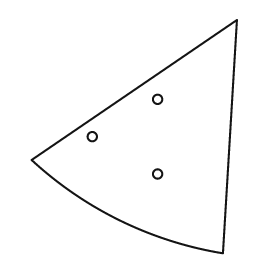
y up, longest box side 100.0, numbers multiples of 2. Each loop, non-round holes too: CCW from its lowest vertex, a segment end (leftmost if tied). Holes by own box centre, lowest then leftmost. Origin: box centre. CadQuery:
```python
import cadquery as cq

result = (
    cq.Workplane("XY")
    .moveTo(38.0, -50.0)
    .lineTo(44.0, 50.0)
    .lineTo(-44.0, -10.0)
    .threePointArc((-6.0, -36.0), (38.0, -50.0))
    .close()
    .moveTo(10.0, -16.0)
    .circle(2.0)
    .moveTo(-18.0, 0.0)
    .circle(2.0)
    .moveTo(10.0, 16.0)
    .circle(2.0)
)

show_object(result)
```